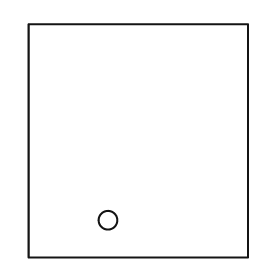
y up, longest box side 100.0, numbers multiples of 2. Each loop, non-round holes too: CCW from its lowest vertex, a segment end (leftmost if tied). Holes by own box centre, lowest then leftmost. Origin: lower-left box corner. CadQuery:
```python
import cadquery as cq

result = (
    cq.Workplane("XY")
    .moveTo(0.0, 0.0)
    .lineTo(94.0, 0.0)
    .lineTo(94.0, 100.0)
    .lineTo(0.0, 100.0)
    .close()
    .moveTo(34.0, 16.0)
    .circle(4.0)
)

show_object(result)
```